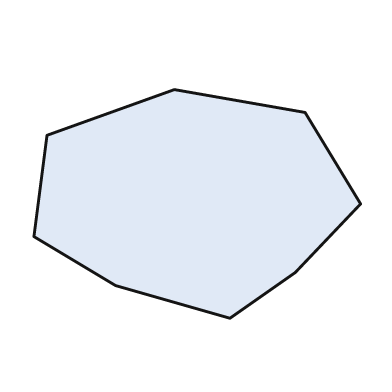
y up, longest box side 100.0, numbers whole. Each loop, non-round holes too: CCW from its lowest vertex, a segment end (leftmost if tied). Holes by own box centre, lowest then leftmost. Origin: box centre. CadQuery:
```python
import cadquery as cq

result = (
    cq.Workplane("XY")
    .moveTo(10.0, -35.0)
    .lineTo(30.0, -21.0)
    .lineTo(50.0, 0.0)
    .lineTo(33.0, 28.0)
    .lineTo(-7.0, 35.0)
    .lineTo(-46.0, 21.0)
    .lineTo(-50.0, -10.0)
    .lineTo(-25.0, -25.0)
    .close()
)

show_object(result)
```